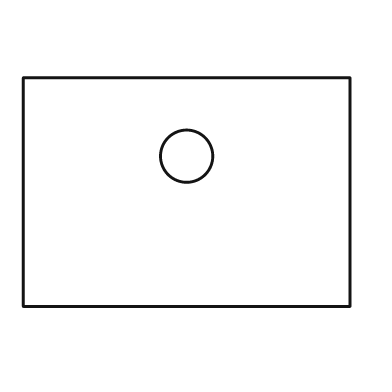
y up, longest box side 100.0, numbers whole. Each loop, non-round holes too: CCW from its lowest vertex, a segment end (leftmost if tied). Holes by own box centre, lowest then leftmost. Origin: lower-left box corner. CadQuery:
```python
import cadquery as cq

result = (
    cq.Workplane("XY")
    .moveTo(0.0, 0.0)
    .lineTo(100.0, 0.0)
    .lineTo(100.0, 70.0)
    .lineTo(0.0, 70.0)
    .close()
    .moveTo(50.0, 46.0)
    .circle(8.0)
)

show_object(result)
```